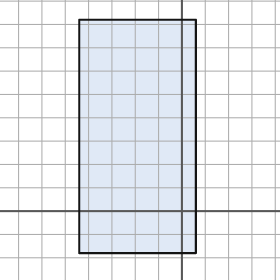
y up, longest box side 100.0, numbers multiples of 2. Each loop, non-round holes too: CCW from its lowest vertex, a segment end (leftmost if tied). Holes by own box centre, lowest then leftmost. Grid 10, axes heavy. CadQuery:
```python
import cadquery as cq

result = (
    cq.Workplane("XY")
    .moveTo(-44.0, -18.0)
    .lineTo(6.0, -18.0)
    .lineTo(6.0, 82.0)
    .lineTo(-44.0, 82.0)
    .close()
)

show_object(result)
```